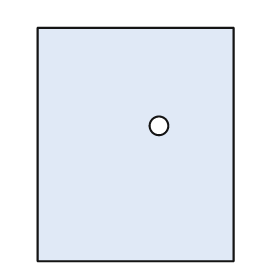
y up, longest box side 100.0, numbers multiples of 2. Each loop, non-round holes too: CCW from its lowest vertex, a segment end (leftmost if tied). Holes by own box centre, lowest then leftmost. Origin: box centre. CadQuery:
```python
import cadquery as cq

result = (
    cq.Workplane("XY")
    .moveTo(-42.0, -50.0)
    .lineTo(42.0, -50.0)
    .lineTo(42.0, 50.0)
    .lineTo(-42.0, 50.0)
    .close()
    .moveTo(10.0, 8.0)
    .circle(4.0)
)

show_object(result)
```